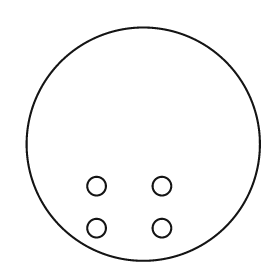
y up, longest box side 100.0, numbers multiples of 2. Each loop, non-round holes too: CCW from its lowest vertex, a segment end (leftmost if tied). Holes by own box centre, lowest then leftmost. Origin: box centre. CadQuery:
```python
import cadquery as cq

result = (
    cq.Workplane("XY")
    .moveTo(0.0, 0.0)
    .circle(50.0)
    .moveTo(-20.0, -36.0)
    .circle(4.0)
    .moveTo(8.0, -36.0)
    .circle(4.0)
    .moveTo(-20.0, -18.0)
    .circle(4.0)
    .moveTo(8.0, -18.0)
    .circle(4.0)
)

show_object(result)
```